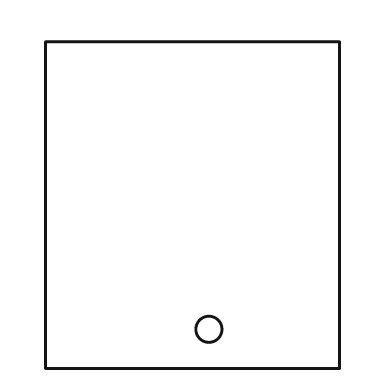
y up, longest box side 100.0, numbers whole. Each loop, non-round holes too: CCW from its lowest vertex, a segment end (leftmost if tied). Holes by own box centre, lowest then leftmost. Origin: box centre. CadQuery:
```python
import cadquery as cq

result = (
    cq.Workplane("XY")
    .moveTo(-45.0, -50.0)
    .lineTo(45.0, -50.0)
    .lineTo(45.0, 50.0)
    .lineTo(-45.0, 50.0)
    .close()
    .moveTo(5.0, -38.0)
    .circle(4.0)
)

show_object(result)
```